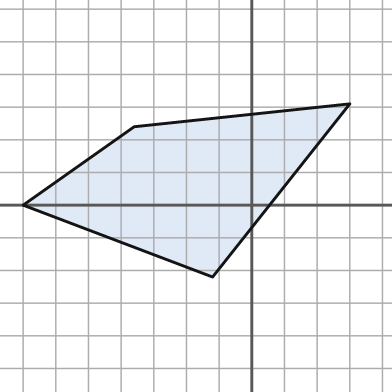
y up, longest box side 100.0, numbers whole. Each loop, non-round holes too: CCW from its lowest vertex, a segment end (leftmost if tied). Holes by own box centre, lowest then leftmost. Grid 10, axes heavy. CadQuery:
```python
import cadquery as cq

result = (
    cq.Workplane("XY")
    .moveTo(-12.0, -22.0)
    .lineTo(30.0, 31.0)
    .lineTo(-36.0, 24.0)
    .lineTo(-70.0, 0.0)
    .close()
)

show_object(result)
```